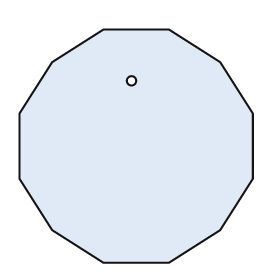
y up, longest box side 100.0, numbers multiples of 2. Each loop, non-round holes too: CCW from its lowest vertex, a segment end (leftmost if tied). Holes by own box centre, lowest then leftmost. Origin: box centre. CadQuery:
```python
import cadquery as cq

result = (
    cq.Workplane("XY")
    .moveTo(-14.0, -50.0)
    .lineTo(14.0, -50.0)
    .lineTo(36.0, -36.0)
    .lineTo(50.0, -14.0)
    .lineTo(50.0, 14.0)
    .lineTo(36.0, 36.0)
    .lineTo(14.0, 50.0)
    .lineTo(-14.0, 50.0)
    .lineTo(-36.0, 36.0)
    .lineTo(-50.0, 14.0)
    .lineTo(-50.0, -14.0)
    .lineTo(-36.0, -36.0)
    .close()
    .moveTo(-2.0, 28.0)
    .circle(2.0)
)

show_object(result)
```